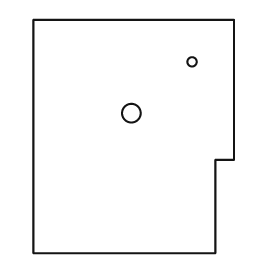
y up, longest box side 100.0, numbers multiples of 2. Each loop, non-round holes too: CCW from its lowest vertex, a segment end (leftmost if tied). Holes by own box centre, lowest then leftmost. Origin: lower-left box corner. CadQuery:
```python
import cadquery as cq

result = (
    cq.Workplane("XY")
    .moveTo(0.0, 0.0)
    .lineTo(78.0, 0.0)
    .lineTo(78.0, 40.0)
    .lineTo(86.0, 40.0)
    .lineTo(86.0, 100.0)
    .lineTo(0.0, 100.0)
    .close()
    .moveTo(42.0, 60.0)
    .circle(4.0)
    .moveTo(68.0, 82.0)
    .circle(2.0)
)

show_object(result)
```